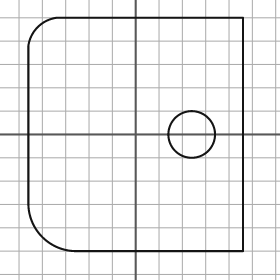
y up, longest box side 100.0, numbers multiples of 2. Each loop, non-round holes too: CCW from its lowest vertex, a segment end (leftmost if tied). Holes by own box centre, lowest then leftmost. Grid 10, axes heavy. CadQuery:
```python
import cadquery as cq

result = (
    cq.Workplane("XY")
    .moveTo(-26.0, -50.0)
    .lineTo(46.0, -50.0)
    .lineTo(46.0, 50.0)
    .lineTo(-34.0, 50.0)
    .threePointArc((-42.0, 46.0), (-46.0, 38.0))
    .lineTo(-46.0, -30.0)
    .threePointArc((-40.0, -44.0), (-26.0, -50.0))
    .close()
    .moveTo(24.0, 0.0)
    .circle(10.0)
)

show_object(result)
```